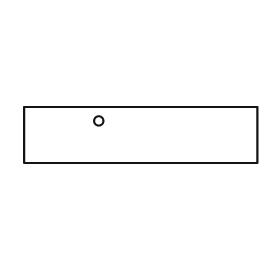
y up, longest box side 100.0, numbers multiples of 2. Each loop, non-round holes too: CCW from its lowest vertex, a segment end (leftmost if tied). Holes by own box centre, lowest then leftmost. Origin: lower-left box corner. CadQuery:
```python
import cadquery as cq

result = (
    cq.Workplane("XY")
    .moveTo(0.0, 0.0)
    .lineTo(100.0, 0.0)
    .lineTo(100.0, 24.0)
    .lineTo(0.0, 24.0)
    .close()
    .moveTo(32.0, 18.0)
    .circle(2.0)
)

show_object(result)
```